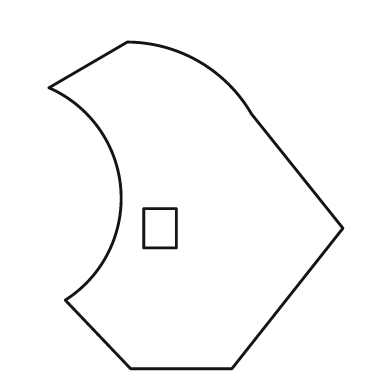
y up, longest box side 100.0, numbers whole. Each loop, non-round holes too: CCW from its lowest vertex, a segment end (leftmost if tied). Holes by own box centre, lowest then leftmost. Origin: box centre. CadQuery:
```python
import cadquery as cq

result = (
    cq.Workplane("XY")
    .moveTo(-20.0, -50.0)
    .lineTo(11.0, -50.0)
    .lineTo(45.0, -7.0)
    .lineTo(17.0, 28.0)
    .threePointArc((1.0, 44.0), (-21.0, 50.0))
    .lineTo(-45.0, 36.0)
    .threePointArc((-23.0, 5.0), (-40.0, -29.0))
    .close()
    .moveTo(-16.0, -13.0)
    .lineTo(-6.0, -13.0)
    .lineTo(-6.0, -1.0)
    .lineTo(-16.0, -1.0)
    .close()
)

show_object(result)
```